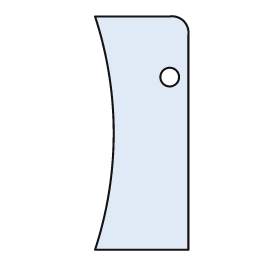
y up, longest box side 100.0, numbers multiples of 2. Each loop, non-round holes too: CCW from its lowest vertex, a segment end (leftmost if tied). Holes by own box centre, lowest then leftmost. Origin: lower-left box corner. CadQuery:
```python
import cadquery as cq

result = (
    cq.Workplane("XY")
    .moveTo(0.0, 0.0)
    .lineTo(40.0, 0.0)
    .lineTo(40.0, 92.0)
    .threePointArc((38.0, 98.0), (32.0, 100.0))
    .lineTo(0.0, 100.0)
    .threePointArc((8.0, 50.0), (0.0, 0.0))
    .close()
    .moveTo(32.0, 74.0)
    .circle(4.0)
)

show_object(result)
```